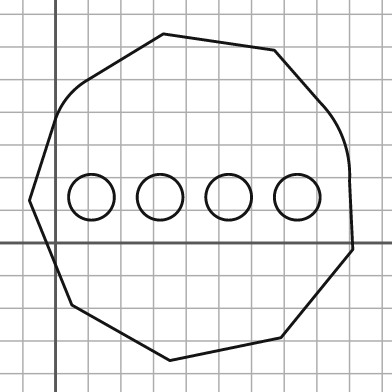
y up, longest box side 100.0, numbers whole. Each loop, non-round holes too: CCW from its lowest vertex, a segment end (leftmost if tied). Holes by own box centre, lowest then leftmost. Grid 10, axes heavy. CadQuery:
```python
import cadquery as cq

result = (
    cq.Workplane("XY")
    .moveTo(35.0, -36.0)
    .lineTo(69.0, -29.0)
    .lineTo(91.0, -2.0)
    .lineTo(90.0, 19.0)
    .threePointArc((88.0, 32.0), (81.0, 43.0))
    .lineTo(67.0, 59.0)
    .lineTo(33.0, 64.0)
    .lineTo(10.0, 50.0)
    .threePointArc((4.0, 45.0), (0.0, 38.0))
    .lineTo(-8.0, 13.0)
    .lineTo(5.0, -19.0)
    .close()
    .moveTo(11.0, 14.0)
    .circle(7.0)
    .moveTo(32.0, 14.0)
    .circle(7.0)
    .moveTo(53.0, 14.0)
    .circle(7.0)
    .moveTo(74.0, 14.0)
    .circle(7.0)
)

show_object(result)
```